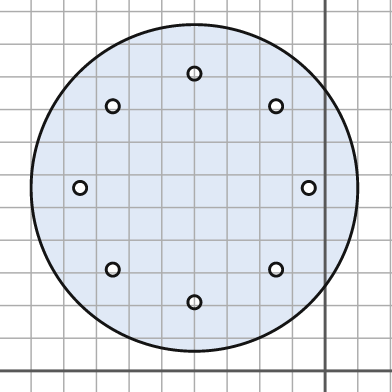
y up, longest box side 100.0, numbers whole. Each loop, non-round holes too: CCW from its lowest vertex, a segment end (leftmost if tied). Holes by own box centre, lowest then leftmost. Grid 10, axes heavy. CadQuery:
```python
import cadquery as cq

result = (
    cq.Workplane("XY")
    .moveTo(-40.0, 56.0)
    .circle(50.0)
    .moveTo(-40.0, 21.0)
    .circle(2.0)
    .moveTo(-65.0, 31.0)
    .circle(2.0)
    .moveTo(-15.0, 31.0)
    .circle(2.0)
    .moveTo(-75.0, 56.0)
    .circle(2.0)
    .moveTo(-5.0, 56.0)
    .circle(2.0)
    .moveTo(-65.0, 81.0)
    .circle(2.0)
    .moveTo(-15.0, 81.0)
    .circle(2.0)
    .moveTo(-40.0, 91.0)
    .circle(2.0)
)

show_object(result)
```